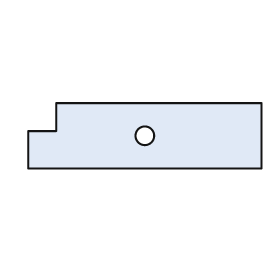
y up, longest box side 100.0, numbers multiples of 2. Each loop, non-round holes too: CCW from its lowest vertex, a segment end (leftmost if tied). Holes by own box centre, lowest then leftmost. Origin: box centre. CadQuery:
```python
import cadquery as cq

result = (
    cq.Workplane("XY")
    .moveTo(-50.0, -14.0)
    .lineTo(50.0, -14.0)
    .lineTo(50.0, 14.0)
    .lineTo(-38.0, 14.0)
    .lineTo(-38.0, 2.0)
    .lineTo(-50.0, 2.0)
    .close()
    .moveTo(0.0, 0.0)
    .circle(4.0)
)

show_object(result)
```